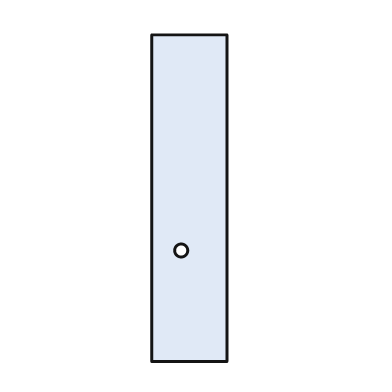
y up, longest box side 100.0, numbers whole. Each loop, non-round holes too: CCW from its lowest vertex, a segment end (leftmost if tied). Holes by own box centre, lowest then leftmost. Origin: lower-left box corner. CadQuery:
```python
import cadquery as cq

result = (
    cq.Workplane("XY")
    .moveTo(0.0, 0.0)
    .lineTo(23.0, 0.0)
    .lineTo(23.0, 100.0)
    .lineTo(0.0, 100.0)
    .close()
    .moveTo(9.0, 34.0)
    .circle(2.0)
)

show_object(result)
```